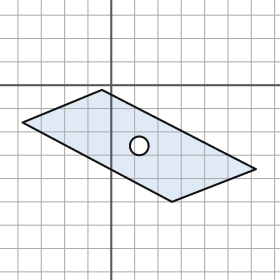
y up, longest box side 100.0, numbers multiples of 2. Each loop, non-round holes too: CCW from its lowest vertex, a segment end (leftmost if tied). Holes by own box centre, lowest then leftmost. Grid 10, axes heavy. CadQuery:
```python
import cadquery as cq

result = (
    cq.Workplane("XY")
    .moveTo(26.0, -50.0)
    .lineTo(62.0, -36.0)
    .lineTo(-4.0, -2.0)
    .lineTo(-38.0, -16.0)
    .close()
    .moveTo(12.0, -26.0)
    .circle(4.0)
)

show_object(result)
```